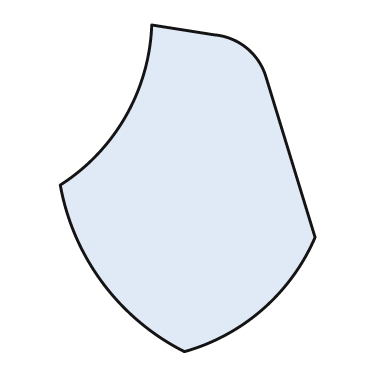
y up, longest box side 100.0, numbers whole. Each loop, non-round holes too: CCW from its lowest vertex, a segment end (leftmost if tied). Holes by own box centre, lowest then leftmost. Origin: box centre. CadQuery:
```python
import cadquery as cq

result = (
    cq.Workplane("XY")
    .moveTo(-1.0, -50.0)
    .threePointArc((23.0, -37.0), (39.0, -15.0))
    .lineTo(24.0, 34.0)
    .threePointArc((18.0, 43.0), (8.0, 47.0))
    .lineTo(-11.0, 50.0)
    .threePointArc((-19.0, 22.0), (-39.0, 1.0))
    .threePointArc((-26.0, -29.0), (-1.0, -50.0))
    .close()
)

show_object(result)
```